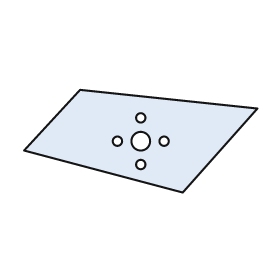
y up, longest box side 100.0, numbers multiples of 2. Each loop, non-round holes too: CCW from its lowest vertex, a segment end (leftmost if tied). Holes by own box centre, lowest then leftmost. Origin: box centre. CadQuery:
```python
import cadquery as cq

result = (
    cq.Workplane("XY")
    .moveTo(18.0, -22.0)
    .lineTo(50.0, 14.0)
    .lineTo(-26.0, 22.0)
    .lineTo(-50.0, -4.0)
    .close()
    .moveTo(0.0, -10.0)
    .circle(2.0)
    .moveTo(-10.0, 0.0)
    .circle(2.0)
    .moveTo(0.0, 0.0)
    .circle(4.0)
    .moveTo(10.0, 0.0)
    .circle(2.0)
    .moveTo(0.0, 10.0)
    .circle(2.0)
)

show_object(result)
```